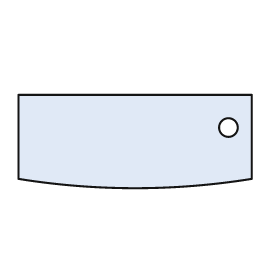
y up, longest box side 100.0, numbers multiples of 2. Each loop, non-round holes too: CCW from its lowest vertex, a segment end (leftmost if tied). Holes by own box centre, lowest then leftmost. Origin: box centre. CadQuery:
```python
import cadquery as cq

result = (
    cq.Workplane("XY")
    .moveTo(-50.0, -16.0)
    .threePointArc((0.0, -20.0), (50.0, -16.0))
    .lineTo(50.0, 20.0)
    .lineTo(-50.0, 20.0)
    .close()
    .moveTo(40.0, 6.0)
    .circle(4.0)
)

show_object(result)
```